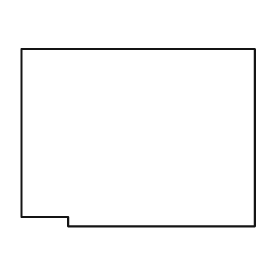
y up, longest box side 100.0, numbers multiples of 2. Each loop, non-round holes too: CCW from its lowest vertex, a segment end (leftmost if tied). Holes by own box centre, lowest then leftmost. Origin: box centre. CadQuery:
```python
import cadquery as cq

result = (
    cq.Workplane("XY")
    .moveTo(-30.0, -38.0)
    .lineTo(50.0, -38.0)
    .lineTo(50.0, 38.0)
    .lineTo(-50.0, 38.0)
    .lineTo(-50.0, -34.0)
    .lineTo(-30.0, -34.0)
    .close()
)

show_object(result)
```